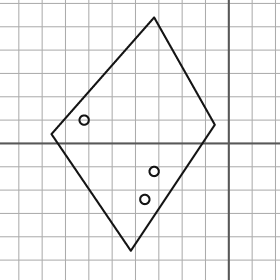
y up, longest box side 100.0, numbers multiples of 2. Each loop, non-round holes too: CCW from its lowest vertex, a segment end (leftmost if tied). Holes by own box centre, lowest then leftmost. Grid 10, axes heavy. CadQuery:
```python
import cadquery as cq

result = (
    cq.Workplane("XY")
    .moveTo(-42.0, -46.0)
    .lineTo(-6.0, 8.0)
    .lineTo(-32.0, 54.0)
    .lineTo(-76.0, 4.0)
    .close()
    .moveTo(-36.0, -24.0)
    .circle(2.0)
    .moveTo(-32.0, -12.0)
    .circle(2.0)
    .moveTo(-62.0, 10.0)
    .circle(2.0)
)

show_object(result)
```